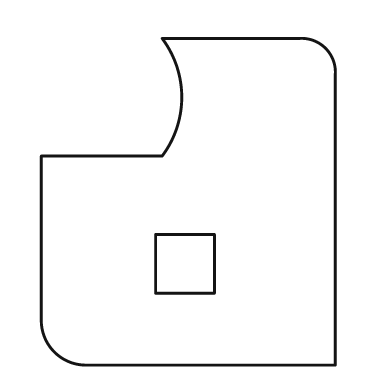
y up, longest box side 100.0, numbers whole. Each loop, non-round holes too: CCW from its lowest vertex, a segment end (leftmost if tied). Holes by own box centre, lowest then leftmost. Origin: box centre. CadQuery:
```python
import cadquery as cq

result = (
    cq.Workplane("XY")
    .moveTo(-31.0, -50.0)
    .lineTo(45.0, -50.0)
    .lineTo(45.0, 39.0)
    .threePointArc((42.0, 47.0), (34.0, 50.0))
    .lineTo(-8.0, 50.0)
    .threePointArc((-2.0, 32.0), (-8.0, 14.0))
    .lineTo(-45.0, 14.0)
    .lineTo(-45.0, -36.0)
    .threePointArc((-41.0, -46.0), (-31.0, -50.0))
    .close()
    .moveTo(-10.0, -28.0)
    .lineTo(8.0, -28.0)
    .lineTo(8.0, -10.0)
    .lineTo(-10.0, -10.0)
    .close()
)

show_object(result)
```